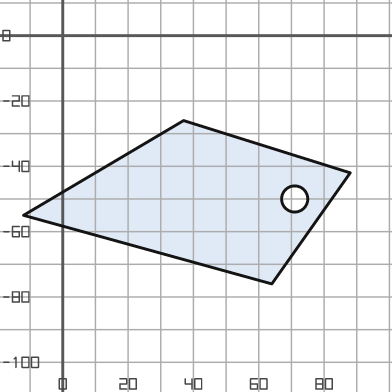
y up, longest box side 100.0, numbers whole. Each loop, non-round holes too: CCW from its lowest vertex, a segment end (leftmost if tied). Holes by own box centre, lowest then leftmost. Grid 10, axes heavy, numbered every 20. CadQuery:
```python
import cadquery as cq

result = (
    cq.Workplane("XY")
    .moveTo(64.0, -76.0)
    .lineTo(88.0, -42.0)
    .lineTo(37.0, -26.0)
    .lineTo(-12.0, -55.0)
    .close()
    .moveTo(71.0, -50.0)
    .circle(4.0)
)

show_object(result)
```